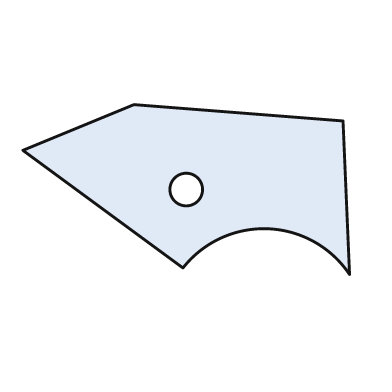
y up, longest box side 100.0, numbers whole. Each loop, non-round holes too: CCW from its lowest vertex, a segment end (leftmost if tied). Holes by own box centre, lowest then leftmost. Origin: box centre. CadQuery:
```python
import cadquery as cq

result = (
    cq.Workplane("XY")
    .moveTo(50.0, -26.0)
    .lineTo(48.0, 21.0)
    .lineTo(-16.0, 26.0)
    .lineTo(-50.0, 12.0)
    .lineTo(-1.0, -24.0)
    .threePointArc((25.0, -12.0), (50.0, -26.0))
    .close()
    .moveTo(0.0, 0.0)
    .circle(5.0)
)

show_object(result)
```